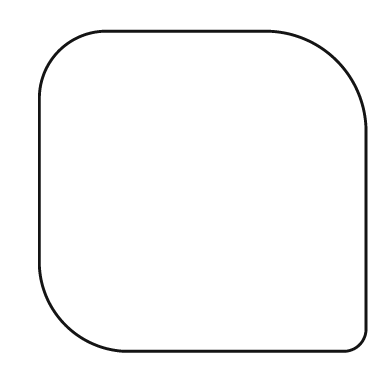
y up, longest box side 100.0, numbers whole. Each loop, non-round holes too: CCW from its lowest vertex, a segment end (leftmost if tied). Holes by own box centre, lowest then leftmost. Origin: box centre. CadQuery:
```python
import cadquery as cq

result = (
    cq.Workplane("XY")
    .moveTo(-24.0, -49.0)
    .lineTo(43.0, -49.0)
    .threePointArc((48.0, -47.0), (50.0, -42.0))
    .lineTo(50.0, 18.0)
    .threePointArc((41.0, 40.0), (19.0, 49.0))
    .lineTo(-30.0, 49.0)
    .threePointArc((-44.0, 43.0), (-50.0, 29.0))
    .lineTo(-50.0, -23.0)
    .threePointArc((-42.0, -41.0), (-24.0, -49.0))
    .close()
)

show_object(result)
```